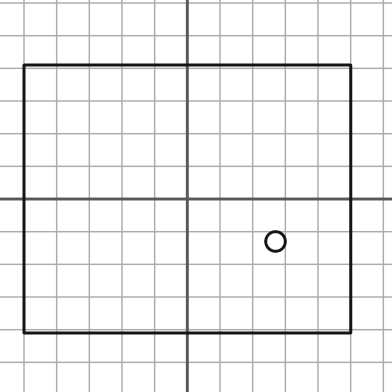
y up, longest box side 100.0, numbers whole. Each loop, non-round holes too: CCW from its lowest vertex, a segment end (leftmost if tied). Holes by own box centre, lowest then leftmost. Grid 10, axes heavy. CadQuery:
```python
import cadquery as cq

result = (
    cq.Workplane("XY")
    .moveTo(-50.0, -41.0)
    .lineTo(50.0, -41.0)
    .lineTo(50.0, 41.0)
    .lineTo(-50.0, 41.0)
    .close()
    .moveTo(27.0, -13.0)
    .circle(3.0)
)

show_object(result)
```